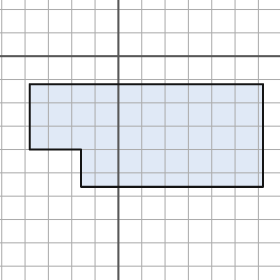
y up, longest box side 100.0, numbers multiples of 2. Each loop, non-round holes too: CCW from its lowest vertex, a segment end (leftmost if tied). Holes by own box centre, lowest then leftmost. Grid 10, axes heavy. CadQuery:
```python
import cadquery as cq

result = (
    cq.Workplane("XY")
    .moveTo(-16.0, -56.0)
    .lineTo(62.0, -56.0)
    .lineTo(62.0, -12.0)
    .lineTo(-38.0, -12.0)
    .lineTo(-38.0, -40.0)
    .lineTo(-16.0, -40.0)
    .close()
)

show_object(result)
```